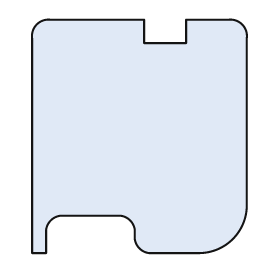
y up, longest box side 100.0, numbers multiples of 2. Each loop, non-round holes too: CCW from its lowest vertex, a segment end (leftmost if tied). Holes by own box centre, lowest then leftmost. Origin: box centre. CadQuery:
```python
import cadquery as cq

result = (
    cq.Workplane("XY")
    .moveTo(-46.0, -50.0)
    .lineTo(-40.0, -50.0)
    .lineTo(-40.0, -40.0)
    .threePointArc((-38.0, -36.0), (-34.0, -34.0))
    .lineTo(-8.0, -34.0)
    .threePointArc((-4.0, -36.0), (-2.0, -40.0))
    .lineTo(-2.0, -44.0)
    .threePointArc((0.0, -48.0), (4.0, -50.0))
    .lineTo(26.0, -50.0)
    .threePointArc((40.0, -44.0), (46.0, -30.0))
    .lineTo(46.0, 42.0)
    .threePointArc((44.0, 48.0), (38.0, 50.0))
    .lineTo(20.0, 50.0)
    .lineTo(20.0, 40.0)
    .lineTo(2.0, 40.0)
    .lineTo(2.0, 50.0)
    .lineTo(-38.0, 50.0)
    .threePointArc((-44.0, 48.0), (-46.0, 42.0))
    .close()
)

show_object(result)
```